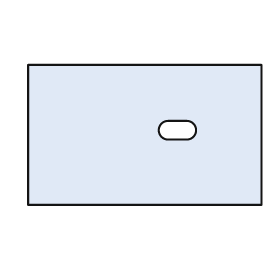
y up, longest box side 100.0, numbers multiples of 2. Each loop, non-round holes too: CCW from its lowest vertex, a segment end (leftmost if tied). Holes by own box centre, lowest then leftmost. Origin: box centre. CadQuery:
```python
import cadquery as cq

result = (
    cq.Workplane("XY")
    .moveTo(-50.0, -30.0)
    .lineTo(50.0, -30.0)
    .lineTo(50.0, 30.0)
    .lineTo(-50.0, 30.0)
    .close()
    .moveTo(10.0, -2.0)
    .lineTo(18.0, -2.0)
    .threePointArc((22.0, 2.0), (18.0, 6.0))
    .lineTo(10.0, 6.0)
    .threePointArc((6.0, 2.0), (10.0, -2.0))
    .close()
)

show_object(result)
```